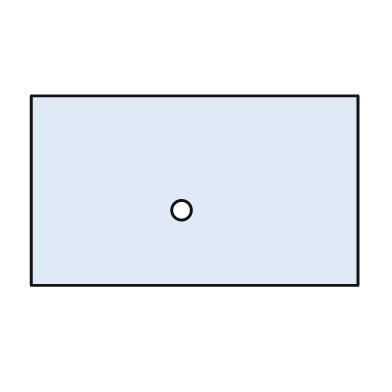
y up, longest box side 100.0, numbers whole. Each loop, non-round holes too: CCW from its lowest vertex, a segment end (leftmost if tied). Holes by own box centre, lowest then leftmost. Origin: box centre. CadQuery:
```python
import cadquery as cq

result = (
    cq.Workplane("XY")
    .moveTo(-50.0, -29.0)
    .lineTo(50.0, -29.0)
    .lineTo(50.0, 29.0)
    .lineTo(-50.0, 29.0)
    .close()
    .moveTo(-4.0, -6.0)
    .circle(3.0)
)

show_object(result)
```